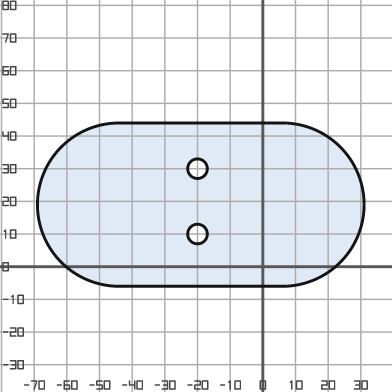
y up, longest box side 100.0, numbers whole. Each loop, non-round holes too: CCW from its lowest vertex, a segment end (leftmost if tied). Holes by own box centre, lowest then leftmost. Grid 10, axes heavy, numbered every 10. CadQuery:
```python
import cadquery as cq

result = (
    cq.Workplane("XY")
    .moveTo(-44.0, -6.0)
    .lineTo(6.0, -6.0)
    .threePointArc((31.0, 19.0), (6.0, 44.0))
    .lineTo(-44.0, 44.0)
    .threePointArc((-69.0, 19.0), (-44.0, -6.0))
    .close()
    .moveTo(-20.0, 10.0)
    .circle(3.0)
    .moveTo(-20.0, 30.0)
    .circle(3.0)
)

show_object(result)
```